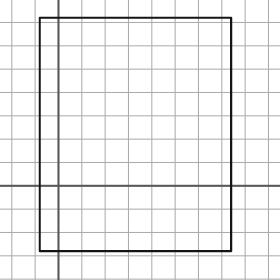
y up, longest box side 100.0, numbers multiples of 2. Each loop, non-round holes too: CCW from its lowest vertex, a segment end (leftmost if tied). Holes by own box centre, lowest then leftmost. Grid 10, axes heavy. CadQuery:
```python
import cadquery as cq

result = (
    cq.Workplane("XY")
    .moveTo(-8.0, -28.0)
    .lineTo(74.0, -28.0)
    .lineTo(74.0, 72.0)
    .lineTo(-8.0, 72.0)
    .close()
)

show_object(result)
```